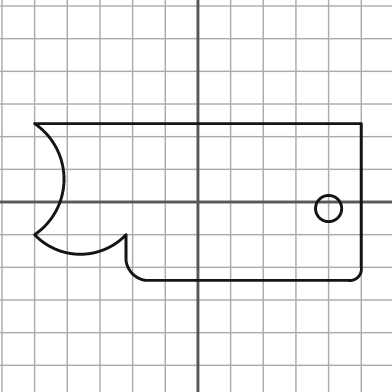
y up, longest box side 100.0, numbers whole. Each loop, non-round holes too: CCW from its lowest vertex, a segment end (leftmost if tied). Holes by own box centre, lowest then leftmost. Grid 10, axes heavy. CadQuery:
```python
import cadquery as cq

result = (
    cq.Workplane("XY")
    .moveTo(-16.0, -24.0)
    .lineTo(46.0, -24.0)
    .threePointArc((49.0, -23.0), (50.0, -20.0))
    .lineTo(50.0, 24.0)
    .lineTo(-50.0, 24.0)
    .threePointArc((-41.0, 7.0), (-50.0, -10.0))
    .threePointArc((-36.0, -16.0), (-22.0, -10.0))
    .lineTo(-22.0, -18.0)
    .threePointArc((-20.0, -22.0), (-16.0, -24.0))
    .close()
    .moveTo(40.0, -2.0)
    .circle(4.0)
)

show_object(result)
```